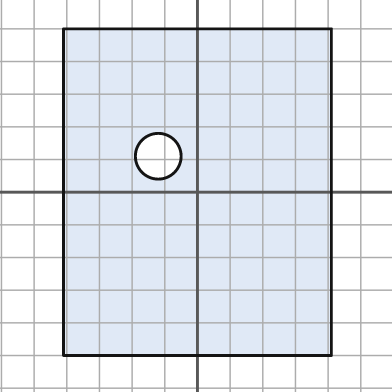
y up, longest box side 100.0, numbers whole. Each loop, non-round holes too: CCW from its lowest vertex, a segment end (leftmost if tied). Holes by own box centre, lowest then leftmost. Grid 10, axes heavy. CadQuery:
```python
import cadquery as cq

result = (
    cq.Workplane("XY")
    .moveTo(-41.0, -50.0)
    .lineTo(41.0, -50.0)
    .lineTo(41.0, 50.0)
    .lineTo(-41.0, 50.0)
    .close()
    .moveTo(-12.0, 11.0)
    .circle(7.0)
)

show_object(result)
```